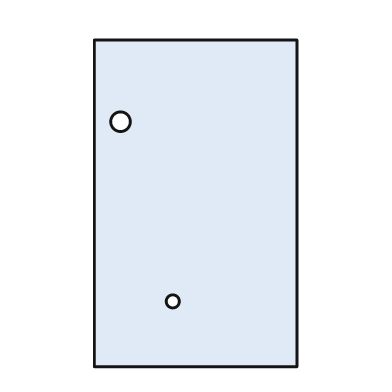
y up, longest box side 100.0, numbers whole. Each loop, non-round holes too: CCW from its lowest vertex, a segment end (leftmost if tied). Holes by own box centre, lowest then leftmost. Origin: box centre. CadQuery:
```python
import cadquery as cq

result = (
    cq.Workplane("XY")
    .moveTo(-31.0, -50.0)
    .lineTo(31.0, -50.0)
    .lineTo(31.0, 50.0)
    .lineTo(-31.0, 50.0)
    .close()
    .moveTo(-7.0, -30.0)
    .circle(2.0)
    .moveTo(-23.0, 25.0)
    .circle(3.0)
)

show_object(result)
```